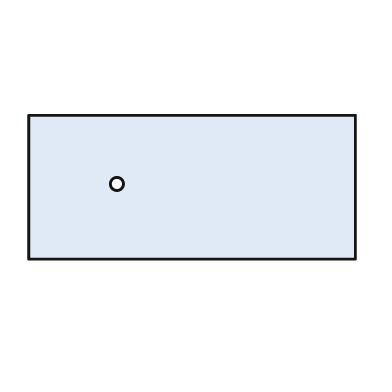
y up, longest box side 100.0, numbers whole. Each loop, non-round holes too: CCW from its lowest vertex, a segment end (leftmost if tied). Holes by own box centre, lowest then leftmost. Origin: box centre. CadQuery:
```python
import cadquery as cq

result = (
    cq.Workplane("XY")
    .moveTo(-50.0, -22.0)
    .lineTo(50.0, -22.0)
    .lineTo(50.0, 22.0)
    .lineTo(-50.0, 22.0)
    .close()
    .moveTo(-23.0, 1.0)
    .circle(2.0)
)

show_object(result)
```